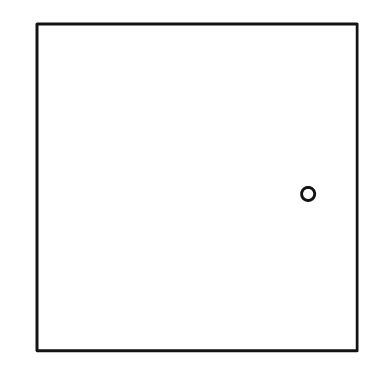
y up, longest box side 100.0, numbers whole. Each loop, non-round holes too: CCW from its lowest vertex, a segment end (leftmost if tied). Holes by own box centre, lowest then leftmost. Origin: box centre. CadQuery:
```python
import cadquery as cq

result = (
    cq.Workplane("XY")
    .moveTo(-49.0, -50.0)
    .lineTo(49.0, -50.0)
    .lineTo(49.0, 50.0)
    .lineTo(-49.0, 50.0)
    .close()
    .moveTo(34.0, -2.0)
    .circle(2.0)
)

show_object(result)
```